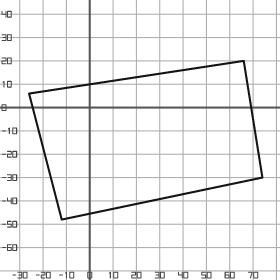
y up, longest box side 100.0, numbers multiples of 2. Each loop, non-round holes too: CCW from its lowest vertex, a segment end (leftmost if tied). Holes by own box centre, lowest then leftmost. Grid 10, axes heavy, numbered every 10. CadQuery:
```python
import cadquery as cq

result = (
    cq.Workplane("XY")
    .moveTo(-12.0, -48.0)
    .lineTo(74.0, -30.0)
    .lineTo(66.0, 20.0)
    .lineTo(-26.0, 6.0)
    .close()
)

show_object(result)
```